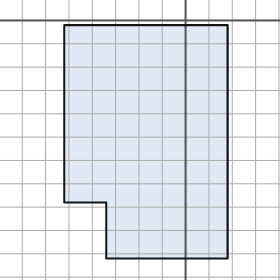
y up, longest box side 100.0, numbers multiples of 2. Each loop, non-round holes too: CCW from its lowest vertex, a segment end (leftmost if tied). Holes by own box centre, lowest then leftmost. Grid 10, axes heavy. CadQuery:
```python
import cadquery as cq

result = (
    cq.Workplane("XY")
    .moveTo(-34.0, -102.0)
    .lineTo(18.0, -102.0)
    .lineTo(18.0, -2.0)
    .lineTo(-52.0, -2.0)
    .lineTo(-52.0, -78.0)
    .lineTo(-34.0, -78.0)
    .close()
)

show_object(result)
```